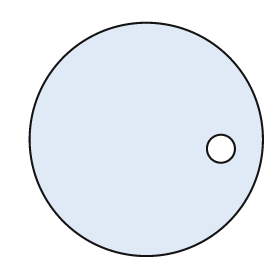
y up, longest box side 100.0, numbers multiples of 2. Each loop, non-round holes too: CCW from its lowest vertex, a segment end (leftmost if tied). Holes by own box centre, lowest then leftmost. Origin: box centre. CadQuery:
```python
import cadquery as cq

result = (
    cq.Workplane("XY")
    .moveTo(0.0, 0.0)
    .circle(50.0)
    .moveTo(32.0, -4.0)
    .circle(6.0)
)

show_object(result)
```